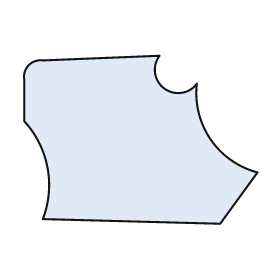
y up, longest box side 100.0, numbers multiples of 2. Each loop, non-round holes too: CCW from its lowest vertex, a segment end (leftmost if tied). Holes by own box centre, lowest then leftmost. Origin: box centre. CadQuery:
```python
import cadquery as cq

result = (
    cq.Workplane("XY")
    .moveTo(34.0, -36.0)
    .lineTo(50.0, -14.0)
    .threePointArc((30.0, 0.0), (24.0, 24.0))
    .threePointArc((10.0, 22.0), (8.0, 36.0))
    .lineTo(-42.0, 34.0)
    .threePointArc((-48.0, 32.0), (-50.0, 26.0))
    .lineTo(-50.0, 8.0)
    .threePointArc((-40.0, -12.0), (-42.0, -34.0))
    .close()
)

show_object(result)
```